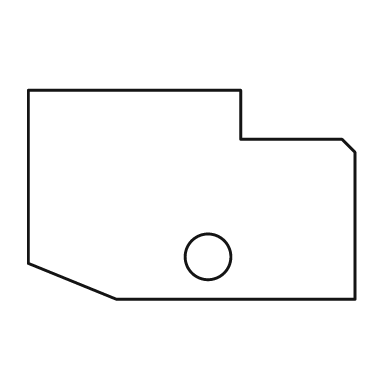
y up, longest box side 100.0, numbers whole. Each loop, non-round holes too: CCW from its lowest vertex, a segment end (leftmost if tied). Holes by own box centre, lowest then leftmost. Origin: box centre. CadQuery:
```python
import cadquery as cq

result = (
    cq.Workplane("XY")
    .moveTo(-23.0, -32.0)
    .lineTo(50.0, -32.0)
    .lineTo(50.0, 13.0)
    .lineTo(46.0, 17.0)
    .lineTo(15.0, 17.0)
    .lineTo(15.0, 32.0)
    .lineTo(-50.0, 32.0)
    .lineTo(-50.0, -21.0)
    .close()
    .moveTo(5.0, -19.0)
    .circle(7.0)
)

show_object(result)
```